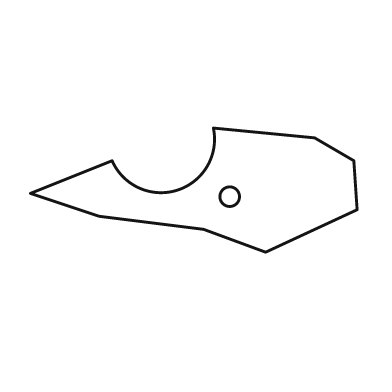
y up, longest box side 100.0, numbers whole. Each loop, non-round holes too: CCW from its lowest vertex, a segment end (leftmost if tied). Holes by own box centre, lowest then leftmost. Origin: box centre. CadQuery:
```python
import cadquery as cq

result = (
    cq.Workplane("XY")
    .moveTo(22.0, -19.0)
    .lineTo(50.0, -6.0)
    .lineTo(49.0, 9.0)
    .lineTo(37.0, 16.0)
    .lineTo(6.0, 19.0)
    .threePointArc((-5.0, 0.0), (-25.0, 9.0))
    .lineTo(-50.0, -1.0)
    .lineTo(-29.0, -8.0)
    .lineTo(3.0, -12.0)
    .close()
    .moveTo(11.0, -2.0)
    .circle(3.0)
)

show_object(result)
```